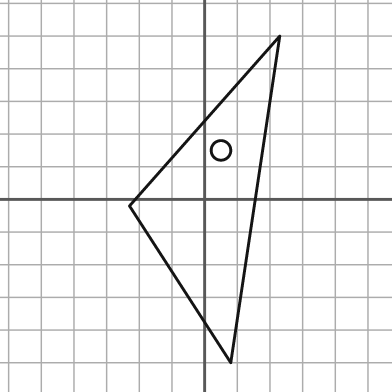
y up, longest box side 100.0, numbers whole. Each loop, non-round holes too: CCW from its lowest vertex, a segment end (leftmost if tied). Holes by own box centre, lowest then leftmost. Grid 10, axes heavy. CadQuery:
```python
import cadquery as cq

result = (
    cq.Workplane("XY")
    .moveTo(8.0, -50.0)
    .lineTo(23.0, 50.0)
    .lineTo(-23.0, -2.0)
    .close()
    .moveTo(5.0, 15.0)
    .circle(3.0)
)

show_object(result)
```